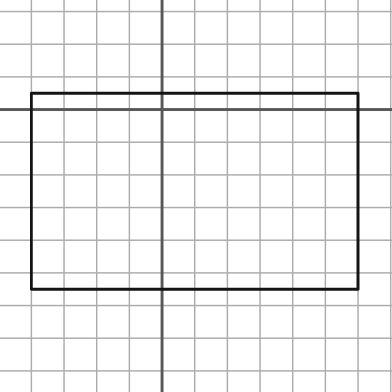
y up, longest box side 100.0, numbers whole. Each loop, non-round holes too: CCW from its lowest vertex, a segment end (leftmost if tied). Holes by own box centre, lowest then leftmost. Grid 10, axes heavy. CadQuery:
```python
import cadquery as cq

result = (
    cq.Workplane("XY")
    .moveTo(-40.0, -55.0)
    .lineTo(60.0, -55.0)
    .lineTo(60.0, 5.0)
    .lineTo(-40.0, 5.0)
    .close()
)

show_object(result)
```